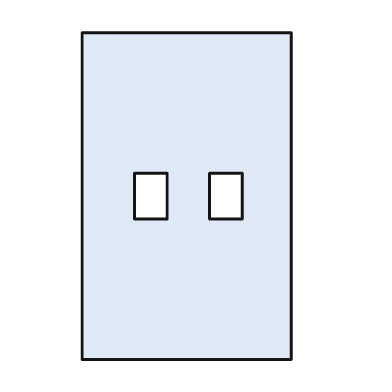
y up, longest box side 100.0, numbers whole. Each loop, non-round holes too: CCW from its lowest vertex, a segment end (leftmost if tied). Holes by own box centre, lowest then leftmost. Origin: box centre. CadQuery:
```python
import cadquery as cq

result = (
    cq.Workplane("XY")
    .moveTo(-32.0, -50.0)
    .lineTo(32.0, -50.0)
    .lineTo(32.0, 50.0)
    .lineTo(-32.0, 50.0)
    .close()
    .moveTo(-16.0, -7.0)
    .lineTo(-6.0, -7.0)
    .lineTo(-6.0, 7.0)
    .lineTo(-16.0, 7.0)
    .close()
    .moveTo(7.0, -7.0)
    .lineTo(17.0, -7.0)
    .lineTo(17.0, 7.0)
    .lineTo(7.0, 7.0)
    .close()
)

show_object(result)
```